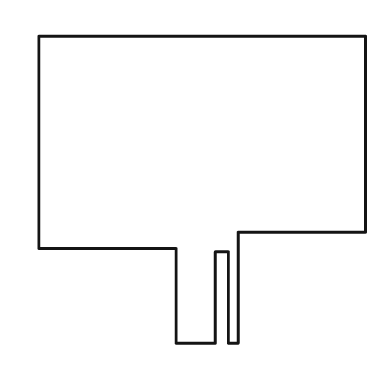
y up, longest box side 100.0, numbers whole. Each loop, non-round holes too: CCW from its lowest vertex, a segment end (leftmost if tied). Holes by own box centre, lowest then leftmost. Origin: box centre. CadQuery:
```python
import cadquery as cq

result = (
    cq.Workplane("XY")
    .moveTo(-8.0, -47.0)
    .lineTo(4.0, -47.0)
    .lineTo(4.0, -19.0)
    .lineTo(8.0, -19.0)
    .lineTo(8.0, -47.0)
    .lineTo(11.0, -47.0)
    .lineTo(11.0, -13.0)
    .lineTo(50.0, -13.0)
    .lineTo(50.0, 47.0)
    .lineTo(-50.0, 47.0)
    .lineTo(-50.0, -18.0)
    .lineTo(-8.0, -18.0)
    .close()
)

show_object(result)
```